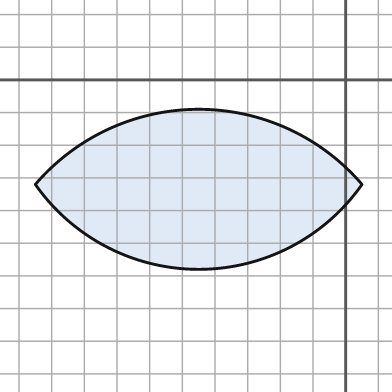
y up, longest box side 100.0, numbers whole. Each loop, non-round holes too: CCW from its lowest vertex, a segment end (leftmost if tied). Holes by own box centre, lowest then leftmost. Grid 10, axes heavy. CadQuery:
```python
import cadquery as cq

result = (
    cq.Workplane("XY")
    .moveTo(-95.0, -32.0)
    .threePointArc((-45.0, -58.0), (5.0, -32.0))
    .threePointArc((-45.0, -9.0), (-95.0, -32.0))
    .close()
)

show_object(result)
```